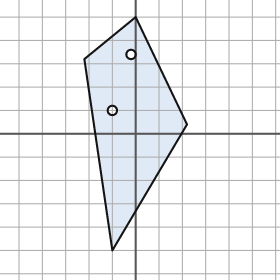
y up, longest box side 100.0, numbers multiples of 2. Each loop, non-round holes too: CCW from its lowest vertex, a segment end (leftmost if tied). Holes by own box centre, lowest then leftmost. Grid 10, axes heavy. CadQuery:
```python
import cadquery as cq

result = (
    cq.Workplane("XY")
    .moveTo(-10.0, -50.0)
    .lineTo(22.0, 4.0)
    .lineTo(0.0, 50.0)
    .lineTo(-22.0, 32.0)
    .close()
    .moveTo(-10.0, 10.0)
    .circle(2.0)
    .moveTo(-2.0, 34.0)
    .circle(2.0)
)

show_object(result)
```